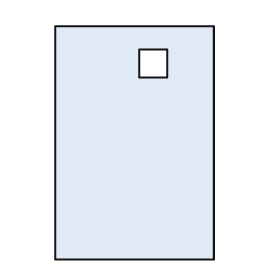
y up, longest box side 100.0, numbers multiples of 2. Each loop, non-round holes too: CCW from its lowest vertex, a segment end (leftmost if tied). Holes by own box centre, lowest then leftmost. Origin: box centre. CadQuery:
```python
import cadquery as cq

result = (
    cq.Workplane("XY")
    .moveTo(-34.0, -50.0)
    .lineTo(34.0, -50.0)
    .lineTo(34.0, 50.0)
    .lineTo(-34.0, 50.0)
    .close()
    .moveTo(2.0, 28.0)
    .lineTo(14.0, 28.0)
    .lineTo(14.0, 40.0)
    .lineTo(2.0, 40.0)
    .close()
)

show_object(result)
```